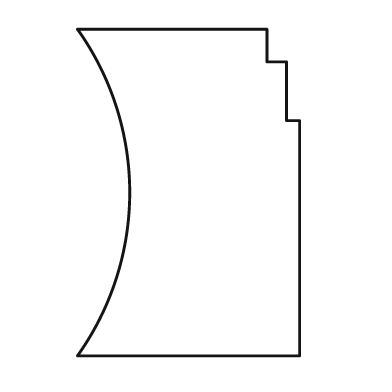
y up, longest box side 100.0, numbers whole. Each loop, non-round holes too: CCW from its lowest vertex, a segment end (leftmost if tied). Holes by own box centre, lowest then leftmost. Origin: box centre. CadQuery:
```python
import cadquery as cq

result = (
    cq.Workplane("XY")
    .moveTo(-34.0, -50.0)
    .lineTo(34.0, -50.0)
    .lineTo(34.0, 22.0)
    .lineTo(30.0, 22.0)
    .lineTo(30.0, 40.0)
    .lineTo(24.0, 40.0)
    .lineTo(24.0, 50.0)
    .lineTo(-34.0, 50.0)
    .threePointArc((-18.0, 0.0), (-34.0, -50.0))
    .close()
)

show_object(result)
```